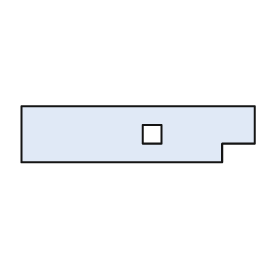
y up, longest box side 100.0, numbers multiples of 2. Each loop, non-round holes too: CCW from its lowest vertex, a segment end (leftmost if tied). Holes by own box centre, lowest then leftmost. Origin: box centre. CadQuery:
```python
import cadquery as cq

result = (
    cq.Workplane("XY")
    .moveTo(-50.0, -12.0)
    .lineTo(36.0, -12.0)
    .lineTo(36.0, -4.0)
    .lineTo(50.0, -4.0)
    .lineTo(50.0, 12.0)
    .lineTo(-50.0, 12.0)
    .close()
    .moveTo(2.0, -4.0)
    .lineTo(10.0, -4.0)
    .lineTo(10.0, 4.0)
    .lineTo(2.0, 4.0)
    .close()
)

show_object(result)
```